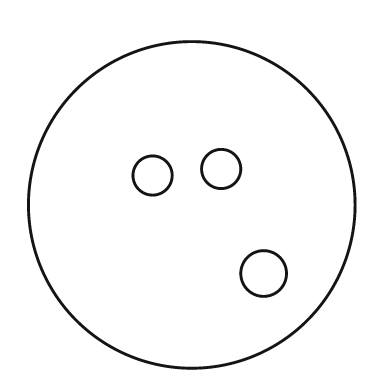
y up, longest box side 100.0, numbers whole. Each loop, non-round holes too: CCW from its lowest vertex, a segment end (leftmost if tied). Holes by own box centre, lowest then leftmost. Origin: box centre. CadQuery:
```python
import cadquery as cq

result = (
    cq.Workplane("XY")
    .moveTo(0.0, 0.0)
    .circle(50.0)
    .moveTo(22.0, -21.0)
    .circle(7.0)
    .moveTo(-12.0, 9.0)
    .circle(6.0)
    .moveTo(9.0, 11.0)
    .circle(6.0)
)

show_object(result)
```